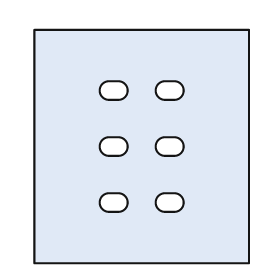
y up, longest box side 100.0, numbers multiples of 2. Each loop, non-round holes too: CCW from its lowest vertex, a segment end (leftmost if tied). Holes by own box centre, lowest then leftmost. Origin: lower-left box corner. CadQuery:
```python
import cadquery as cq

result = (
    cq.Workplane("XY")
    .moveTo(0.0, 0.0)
    .lineTo(92.0, 0.0)
    .lineTo(92.0, 100.0)
    .lineTo(0.0, 100.0)
    .close()
    .moveTo(32.0, 22.0)
    .lineTo(36.0, 22.0)
    .threePointArc((40.0, 26.0), (36.0, 30.0))
    .lineTo(32.0, 30.0)
    .threePointArc((28.0, 26.0), (32.0, 22.0))
    .close()
    .moveTo(56.0, 22.0)
    .lineTo(60.0, 22.0)
    .threePointArc((64.0, 26.0), (60.0, 30.0))
    .lineTo(56.0, 30.0)
    .threePointArc((52.0, 26.0), (56.0, 22.0))
    .close()
    .moveTo(32.0, 46.0)
    .lineTo(36.0, 46.0)
    .threePointArc((40.0, 50.0), (36.0, 54.0))
    .lineTo(32.0, 54.0)
    .threePointArc((28.0, 50.0), (32.0, 46.0))
    .close()
    .moveTo(56.0, 46.0)
    .lineTo(60.0, 46.0)
    .threePointArc((64.0, 50.0), (60.0, 54.0))
    .lineTo(56.0, 54.0)
    .threePointArc((52.0, 50.0), (56.0, 46.0))
    .close()
    .moveTo(32.0, 70.0)
    .lineTo(36.0, 70.0)
    .threePointArc((40.0, 74.0), (36.0, 78.0))
    .lineTo(32.0, 78.0)
    .threePointArc((28.0, 74.0), (32.0, 70.0))
    .close()
    .moveTo(56.0, 70.0)
    .lineTo(60.0, 70.0)
    .threePointArc((64.0, 74.0), (60.0, 78.0))
    .lineTo(56.0, 78.0)
    .threePointArc((52.0, 74.0), (56.0, 70.0))
    .close()
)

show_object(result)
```